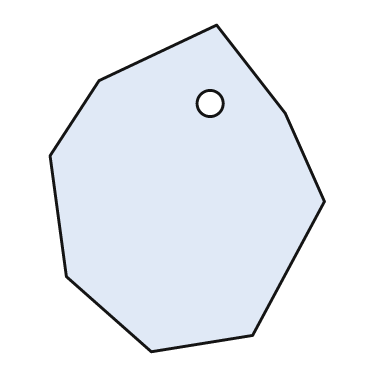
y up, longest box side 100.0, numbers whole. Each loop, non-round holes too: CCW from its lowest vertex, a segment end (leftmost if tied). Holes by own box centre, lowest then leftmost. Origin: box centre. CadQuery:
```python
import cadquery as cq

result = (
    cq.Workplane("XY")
    .moveTo(-11.0, -50.0)
    .lineTo(20.0, -45.0)
    .lineTo(42.0, -4.0)
    .lineTo(30.0, 23.0)
    .lineTo(9.0, 50.0)
    .lineTo(-27.0, 33.0)
    .lineTo(-42.0, 10.0)
    .lineTo(-37.0, -27.0)
    .close()
    .moveTo(7.0, 26.0)
    .circle(4.0)
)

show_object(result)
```